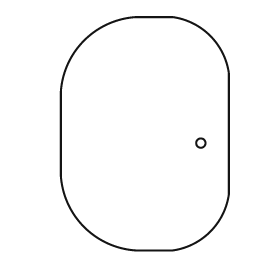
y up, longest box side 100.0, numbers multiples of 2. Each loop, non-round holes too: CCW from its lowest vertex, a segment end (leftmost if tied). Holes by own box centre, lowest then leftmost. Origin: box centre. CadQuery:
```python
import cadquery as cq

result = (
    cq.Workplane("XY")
    .moveTo(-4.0, -50.0)
    .lineTo(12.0, -50.0)
    .threePointArc((28.0, -42.0), (36.0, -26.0))
    .lineTo(36.0, 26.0)
    .threePointArc((28.0, 42.0), (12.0, 50.0))
    .lineTo(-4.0, 50.0)
    .threePointArc((-26.0, 40.0), (-36.0, 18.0))
    .lineTo(-36.0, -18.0)
    .threePointArc((-26.0, -40.0), (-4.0, -50.0))
    .close()
    .moveTo(24.0, -4.0)
    .circle(2.0)
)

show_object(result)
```